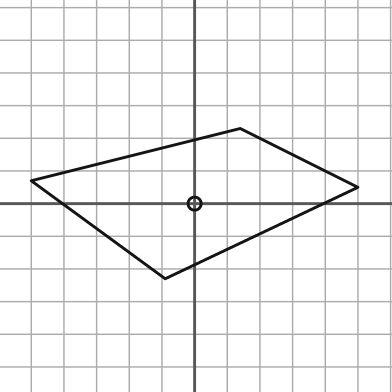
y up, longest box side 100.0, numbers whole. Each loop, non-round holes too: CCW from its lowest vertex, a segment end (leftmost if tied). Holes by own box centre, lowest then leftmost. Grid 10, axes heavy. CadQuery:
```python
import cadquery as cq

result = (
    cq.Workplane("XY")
    .moveTo(-9.0, -23.0)
    .lineTo(50.0, 5.0)
    .lineTo(14.0, 23.0)
    .lineTo(-50.0, 7.0)
    .close()
    .moveTo(0.0, 0.0)
    .circle(2.0)
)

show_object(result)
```